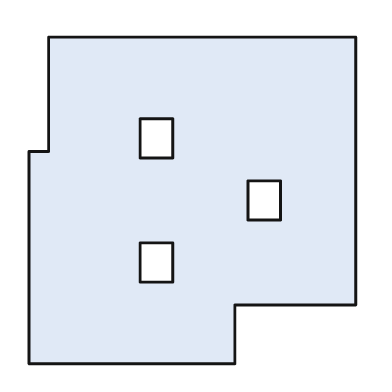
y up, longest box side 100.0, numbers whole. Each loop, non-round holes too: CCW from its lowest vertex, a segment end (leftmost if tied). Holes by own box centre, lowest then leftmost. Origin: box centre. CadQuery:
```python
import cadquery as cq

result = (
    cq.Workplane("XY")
    .moveTo(-50.0, -50.0)
    .lineTo(13.0, -50.0)
    .lineTo(13.0, -32.0)
    .lineTo(50.0, -32.0)
    .lineTo(50.0, 50.0)
    .lineTo(-44.0, 50.0)
    .lineTo(-44.0, 15.0)
    .lineTo(-50.0, 15.0)
    .close()
    .moveTo(-16.0, -25.0)
    .lineTo(-6.0, -25.0)
    .lineTo(-6.0, -13.0)
    .lineTo(-16.0, -13.0)
    .close()
    .moveTo(17.0, -6.0)
    .lineTo(27.0, -6.0)
    .lineTo(27.0, 6.0)
    .lineTo(17.0, 6.0)
    .close()
    .moveTo(-16.0, 13.0)
    .lineTo(-6.0, 13.0)
    .lineTo(-6.0, 25.0)
    .lineTo(-16.0, 25.0)
    .close()
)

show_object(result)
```